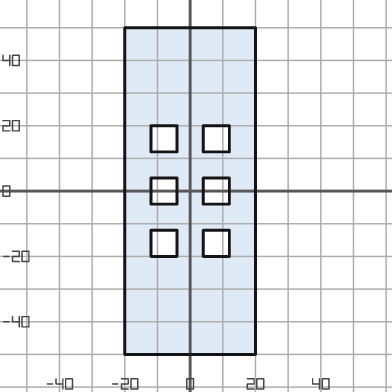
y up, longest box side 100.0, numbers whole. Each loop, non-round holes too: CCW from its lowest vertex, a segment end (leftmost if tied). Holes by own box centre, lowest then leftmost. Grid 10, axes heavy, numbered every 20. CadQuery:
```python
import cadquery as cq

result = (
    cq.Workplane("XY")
    .moveTo(-20.0, -50.0)
    .lineTo(20.0, -50.0)
    .lineTo(20.0, 50.0)
    .lineTo(-20.0, 50.0)
    .close()
    .moveTo(-12.0, -20.0)
    .lineTo(-4.0, -20.0)
    .lineTo(-4.0, -12.0)
    .lineTo(-12.0, -12.0)
    .close()
    .moveTo(4.0, -20.0)
    .lineTo(12.0, -20.0)
    .lineTo(12.0, -12.0)
    .lineTo(4.0, -12.0)
    .close()
    .moveTo(-12.0, -4.0)
    .lineTo(-4.0, -4.0)
    .lineTo(-4.0, 4.0)
    .lineTo(-12.0, 4.0)
    .close()
    .moveTo(4.0, -4.0)
    .lineTo(12.0, -4.0)
    .lineTo(12.0, 4.0)
    .lineTo(4.0, 4.0)
    .close()
    .moveTo(-12.0, 12.0)
    .lineTo(-4.0, 12.0)
    .lineTo(-4.0, 20.0)
    .lineTo(-12.0, 20.0)
    .close()
    .moveTo(4.0, 12.0)
    .lineTo(12.0, 12.0)
    .lineTo(12.0, 20.0)
    .lineTo(4.0, 20.0)
    .close()
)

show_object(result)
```